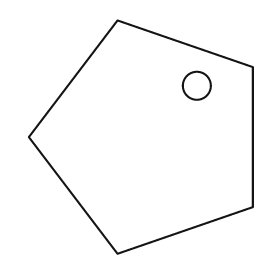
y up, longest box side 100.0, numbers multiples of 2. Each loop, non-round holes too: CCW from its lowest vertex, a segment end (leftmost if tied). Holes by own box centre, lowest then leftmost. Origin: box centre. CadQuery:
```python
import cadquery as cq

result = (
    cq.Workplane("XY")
    .moveTo(-10.0, -50.0)
    .lineTo(48.0, -30.0)
    .lineTo(48.0, 30.0)
    .lineTo(-10.0, 50.0)
    .lineTo(-48.0, 0.0)
    .close()
    .moveTo(24.0, 22.0)
    .circle(6.0)
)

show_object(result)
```